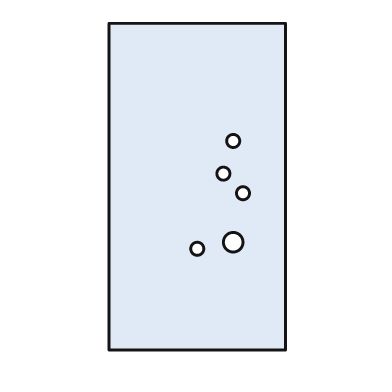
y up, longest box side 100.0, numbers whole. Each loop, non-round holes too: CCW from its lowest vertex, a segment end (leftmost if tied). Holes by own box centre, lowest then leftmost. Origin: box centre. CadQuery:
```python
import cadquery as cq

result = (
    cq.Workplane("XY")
    .moveTo(-27.0, -50.0)
    .lineTo(27.0, -50.0)
    .lineTo(27.0, 50.0)
    .lineTo(-27.0, 50.0)
    .close()
    .moveTo(0.0, -19.0)
    .circle(2.0)
    .moveTo(11.0, -17.0)
    .circle(3.0)
    .moveTo(14.0, -2.0)
    .circle(2.0)
    .moveTo(8.0, 4.0)
    .circle(2.0)
    .moveTo(11.0, 14.0)
    .circle(2.0)
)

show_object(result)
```